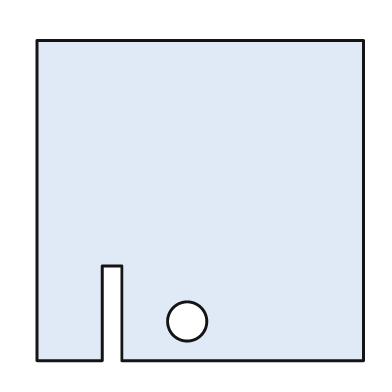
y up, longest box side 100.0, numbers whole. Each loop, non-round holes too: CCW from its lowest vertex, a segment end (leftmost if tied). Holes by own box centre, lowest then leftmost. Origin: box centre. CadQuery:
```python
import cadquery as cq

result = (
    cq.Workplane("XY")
    .moveTo(-50.0, -49.0)
    .lineTo(-30.0, -49.0)
    .lineTo(-30.0, -20.0)
    .lineTo(-24.0, -20.0)
    .lineTo(-24.0, -49.0)
    .lineTo(50.0, -49.0)
    .lineTo(50.0, 49.0)
    .lineTo(-50.0, 49.0)
    .close()
    .moveTo(-4.0, -37.0)
    .circle(6.0)
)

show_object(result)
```